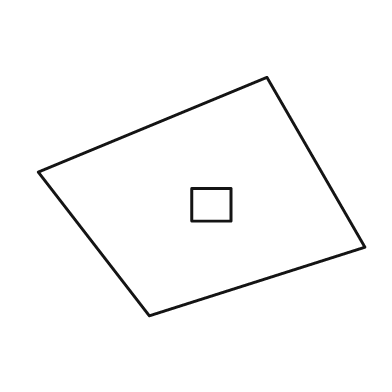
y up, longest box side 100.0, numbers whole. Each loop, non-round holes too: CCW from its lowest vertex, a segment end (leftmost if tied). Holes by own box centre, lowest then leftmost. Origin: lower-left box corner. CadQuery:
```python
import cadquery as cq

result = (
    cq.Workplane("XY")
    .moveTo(34.0, 0.0)
    .lineTo(100.0, 21.0)
    .lineTo(70.0, 73.0)
    .lineTo(0.0, 44.0)
    .close()
    .moveTo(47.0, 29.0)
    .lineTo(59.0, 29.0)
    .lineTo(59.0, 39.0)
    .lineTo(47.0, 39.0)
    .close()
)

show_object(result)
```